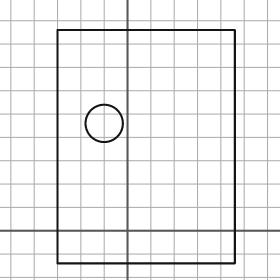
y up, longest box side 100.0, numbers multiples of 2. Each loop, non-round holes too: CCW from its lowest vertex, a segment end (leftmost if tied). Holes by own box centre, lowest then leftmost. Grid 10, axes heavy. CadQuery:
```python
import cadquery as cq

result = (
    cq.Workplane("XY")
    .moveTo(-30.0, -14.0)
    .lineTo(46.0, -14.0)
    .lineTo(46.0, 86.0)
    .lineTo(-30.0, 86.0)
    .close()
    .moveTo(-10.0, 46.0)
    .circle(8.0)
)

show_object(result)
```